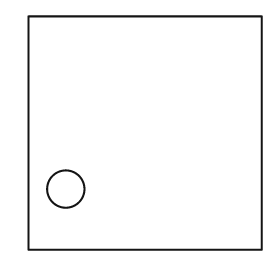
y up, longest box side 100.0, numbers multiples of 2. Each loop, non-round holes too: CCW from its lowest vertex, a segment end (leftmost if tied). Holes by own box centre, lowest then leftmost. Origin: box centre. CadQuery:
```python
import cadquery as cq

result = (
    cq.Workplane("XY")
    .moveTo(-50.0, -50.0)
    .lineTo(50.0, -50.0)
    .lineTo(50.0, 50.0)
    .lineTo(-50.0, 50.0)
    .close()
    .moveTo(-34.0, -24.0)
    .circle(8.0)
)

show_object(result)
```